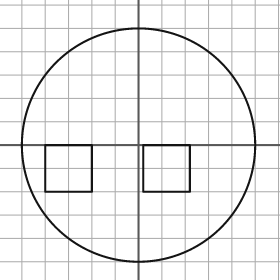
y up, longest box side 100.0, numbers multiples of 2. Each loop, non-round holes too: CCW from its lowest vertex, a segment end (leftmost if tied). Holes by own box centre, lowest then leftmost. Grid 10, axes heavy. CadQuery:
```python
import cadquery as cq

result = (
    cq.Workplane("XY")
    .moveTo(0.0, 0.0)
    .circle(50.0)
    .moveTo(-40.0, -20.0)
    .lineTo(-20.0, -20.0)
    .lineTo(-20.0, 0.0)
    .lineTo(-40.0, 0.0)
    .close()
    .moveTo(2.0, -20.0)
    .lineTo(22.0, -20.0)
    .lineTo(22.0, 0.0)
    .lineTo(2.0, 0.0)
    .close()
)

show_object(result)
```